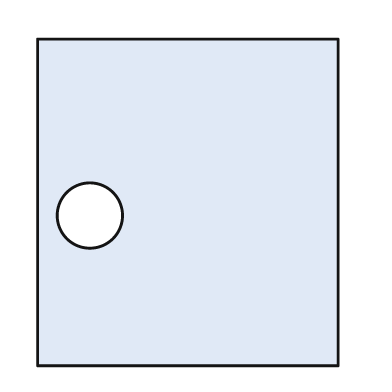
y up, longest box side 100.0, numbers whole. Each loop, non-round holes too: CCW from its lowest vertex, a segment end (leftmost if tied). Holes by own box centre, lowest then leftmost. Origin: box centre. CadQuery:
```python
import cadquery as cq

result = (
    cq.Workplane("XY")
    .moveTo(-46.0, -50.0)
    .lineTo(46.0, -50.0)
    .lineTo(46.0, 50.0)
    .lineTo(-46.0, 50.0)
    .close()
    .moveTo(-30.0, -4.0)
    .circle(10.0)
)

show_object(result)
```